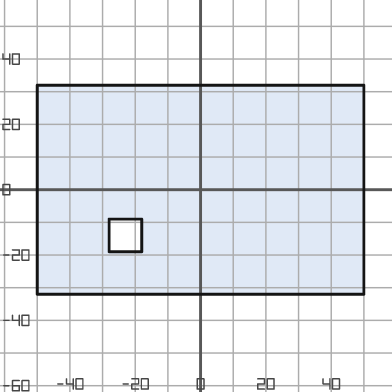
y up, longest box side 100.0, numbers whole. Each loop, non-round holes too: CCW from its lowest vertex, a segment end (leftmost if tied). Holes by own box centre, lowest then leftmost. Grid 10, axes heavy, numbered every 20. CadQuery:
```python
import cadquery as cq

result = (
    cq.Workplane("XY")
    .moveTo(-50.0, -32.0)
    .lineTo(50.0, -32.0)
    .lineTo(50.0, 32.0)
    .lineTo(-50.0, 32.0)
    .close()
    .moveTo(-28.0, -19.0)
    .lineTo(-18.0, -19.0)
    .lineTo(-18.0, -9.0)
    .lineTo(-28.0, -9.0)
    .close()
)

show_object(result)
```